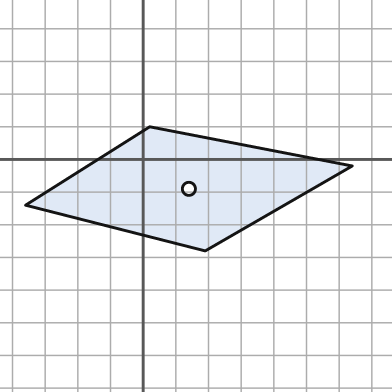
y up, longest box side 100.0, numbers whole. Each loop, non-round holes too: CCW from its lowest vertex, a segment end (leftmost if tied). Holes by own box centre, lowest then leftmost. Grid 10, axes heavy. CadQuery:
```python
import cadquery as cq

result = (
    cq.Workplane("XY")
    .moveTo(19.0, -28.0)
    .lineTo(64.0, -2.0)
    .lineTo(2.0, 10.0)
    .lineTo(-36.0, -14.0)
    .close()
    .moveTo(14.0, -9.0)
    .circle(2.0)
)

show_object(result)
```